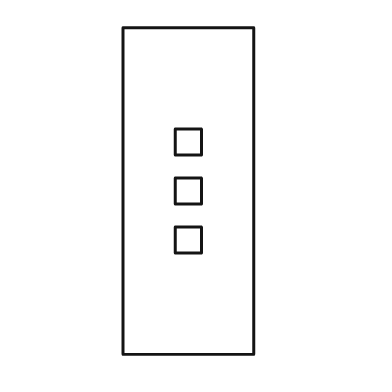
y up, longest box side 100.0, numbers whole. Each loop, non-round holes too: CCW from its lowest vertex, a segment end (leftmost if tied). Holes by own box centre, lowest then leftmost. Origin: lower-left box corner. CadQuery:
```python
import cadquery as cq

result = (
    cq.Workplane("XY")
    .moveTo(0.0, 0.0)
    .lineTo(40.0, 0.0)
    .lineTo(40.0, 100.0)
    .lineTo(0.0, 100.0)
    .close()
    .moveTo(16.0, 31.0)
    .lineTo(24.0, 31.0)
    .lineTo(24.0, 39.0)
    .lineTo(16.0, 39.0)
    .close()
    .moveTo(16.0, 46.0)
    .lineTo(24.0, 46.0)
    .lineTo(24.0, 54.0)
    .lineTo(16.0, 54.0)
    .close()
    .moveTo(16.0, 61.0)
    .lineTo(24.0, 61.0)
    .lineTo(24.0, 69.0)
    .lineTo(16.0, 69.0)
    .close()
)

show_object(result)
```